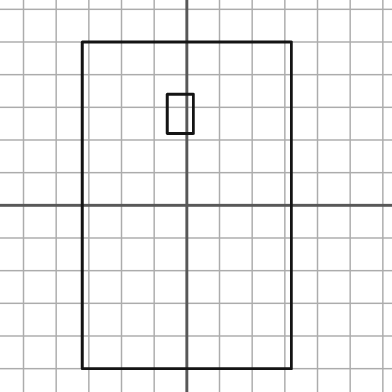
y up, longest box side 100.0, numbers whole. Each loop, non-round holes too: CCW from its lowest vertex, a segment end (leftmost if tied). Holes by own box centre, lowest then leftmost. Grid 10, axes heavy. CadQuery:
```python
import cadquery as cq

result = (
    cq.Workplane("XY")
    .moveTo(-32.0, -50.0)
    .lineTo(32.0, -50.0)
    .lineTo(32.0, 50.0)
    .lineTo(-32.0, 50.0)
    .close()
    .moveTo(-6.0, 22.0)
    .lineTo(2.0, 22.0)
    .lineTo(2.0, 34.0)
    .lineTo(-6.0, 34.0)
    .close()
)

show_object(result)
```